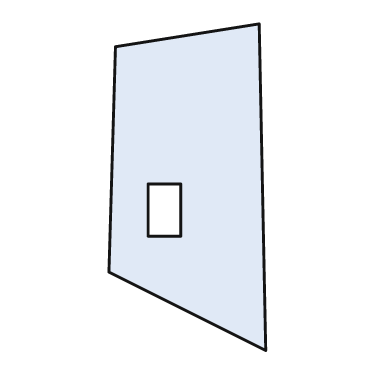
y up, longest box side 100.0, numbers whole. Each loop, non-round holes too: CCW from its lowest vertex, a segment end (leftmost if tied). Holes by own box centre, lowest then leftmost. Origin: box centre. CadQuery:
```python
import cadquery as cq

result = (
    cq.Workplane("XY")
    .moveTo(24.0, -50.0)
    .lineTo(22.0, 50.0)
    .lineTo(-22.0, 43.0)
    .lineTo(-24.0, -26.0)
    .close()
    .moveTo(-12.0, -15.0)
    .lineTo(-2.0, -15.0)
    .lineTo(-2.0, 1.0)
    .lineTo(-12.0, 1.0)
    .close()
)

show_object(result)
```